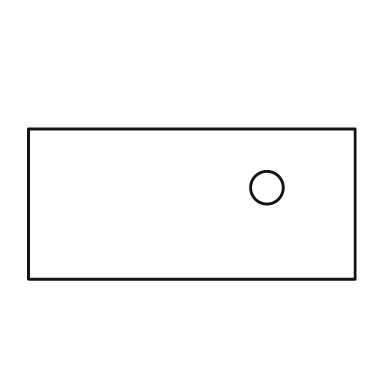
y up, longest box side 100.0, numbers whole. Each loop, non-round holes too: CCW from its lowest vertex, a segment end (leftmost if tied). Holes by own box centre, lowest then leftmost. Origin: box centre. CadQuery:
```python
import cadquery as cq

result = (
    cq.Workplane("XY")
    .moveTo(-50.0, -23.0)
    .lineTo(50.0, -23.0)
    .lineTo(50.0, 23.0)
    .lineTo(-50.0, 23.0)
    .close()
    .moveTo(23.0, 5.0)
    .circle(5.0)
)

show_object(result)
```